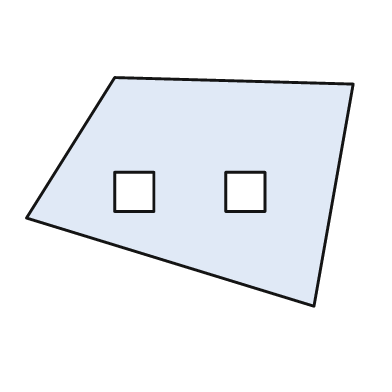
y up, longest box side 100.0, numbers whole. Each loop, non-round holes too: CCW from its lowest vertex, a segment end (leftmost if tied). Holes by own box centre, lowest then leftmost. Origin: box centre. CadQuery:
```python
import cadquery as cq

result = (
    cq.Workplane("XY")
    .moveTo(38.0, -35.0)
    .lineTo(50.0, 33.0)
    .lineTo(-23.0, 35.0)
    .lineTo(-50.0, -8.0)
    .close()
    .moveTo(-23.0, -6.0)
    .lineTo(-11.0, -6.0)
    .lineTo(-11.0, 6.0)
    .lineTo(-23.0, 6.0)
    .close()
    .moveTo(11.0, -6.0)
    .lineTo(23.0, -6.0)
    .lineTo(23.0, 6.0)
    .lineTo(11.0, 6.0)
    .close()
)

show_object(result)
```